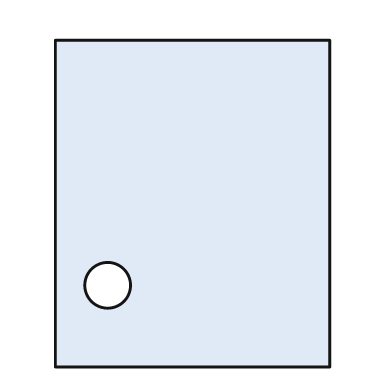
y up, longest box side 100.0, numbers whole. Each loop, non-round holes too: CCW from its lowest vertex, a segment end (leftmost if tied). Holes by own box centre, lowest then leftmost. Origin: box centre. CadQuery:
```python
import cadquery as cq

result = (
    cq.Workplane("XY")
    .moveTo(-42.0, -50.0)
    .lineTo(42.0, -50.0)
    .lineTo(42.0, 50.0)
    .lineTo(-42.0, 50.0)
    .close()
    .moveTo(-26.0, -25.0)
    .circle(7.0)
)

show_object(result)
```